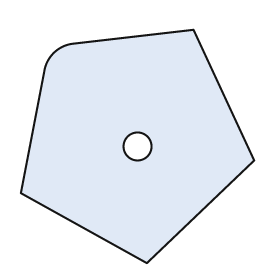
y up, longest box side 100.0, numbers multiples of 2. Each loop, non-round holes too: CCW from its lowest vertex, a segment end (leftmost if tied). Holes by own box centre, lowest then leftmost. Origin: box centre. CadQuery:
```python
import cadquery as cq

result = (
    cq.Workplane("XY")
    .moveTo(4.0, -50.0)
    .lineTo(50.0, -6.0)
    .lineTo(24.0, 50.0)
    .lineTo(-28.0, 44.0)
    .threePointArc((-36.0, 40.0), (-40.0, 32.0))
    .lineTo(-50.0, -20.0)
    .close()
    .moveTo(0.0, 0.0)
    .circle(6.0)
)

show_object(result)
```